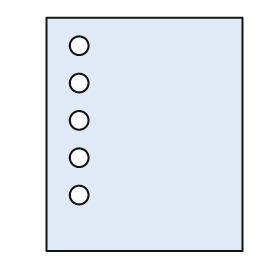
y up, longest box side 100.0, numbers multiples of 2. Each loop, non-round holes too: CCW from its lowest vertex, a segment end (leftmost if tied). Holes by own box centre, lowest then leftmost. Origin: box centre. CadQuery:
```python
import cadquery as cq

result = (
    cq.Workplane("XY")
    .moveTo(-42.0, -50.0)
    .lineTo(42.0, -50.0)
    .lineTo(42.0, 50.0)
    .lineTo(-42.0, 50.0)
    .close()
    .moveTo(-28.0, -26.0)
    .circle(4.0)
    .moveTo(-28.0, -10.0)
    .circle(4.0)
    .moveTo(-28.0, 6.0)
    .circle(4.0)
    .moveTo(-28.0, 22.0)
    .circle(4.0)
    .moveTo(-28.0, 38.0)
    .circle(4.0)
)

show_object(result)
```